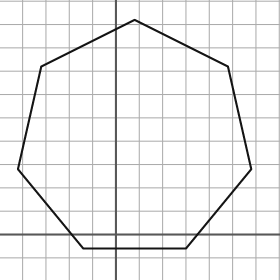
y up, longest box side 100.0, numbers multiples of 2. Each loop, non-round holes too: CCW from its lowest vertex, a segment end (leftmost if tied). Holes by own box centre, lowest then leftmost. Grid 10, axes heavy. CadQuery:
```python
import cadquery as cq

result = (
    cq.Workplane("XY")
    .moveTo(-14.0, -6.0)
    .lineTo(30.0, -6.0)
    .lineTo(58.0, 28.0)
    .lineTo(48.0, 72.0)
    .lineTo(8.0, 92.0)
    .lineTo(-32.0, 72.0)
    .lineTo(-42.0, 28.0)
    .close()
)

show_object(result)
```